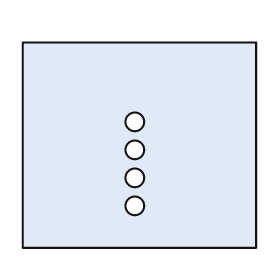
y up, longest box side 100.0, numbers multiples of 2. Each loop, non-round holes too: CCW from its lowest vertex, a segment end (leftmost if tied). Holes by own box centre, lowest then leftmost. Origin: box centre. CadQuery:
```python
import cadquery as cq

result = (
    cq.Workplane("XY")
    .moveTo(-50.0, -44.0)
    .lineTo(50.0, -44.0)
    .lineTo(50.0, 44.0)
    .lineTo(-50.0, 44.0)
    .close()
    .moveTo(-2.0, -26.0)
    .circle(4.0)
    .moveTo(-2.0, -14.0)
    .circle(4.0)
    .moveTo(-2.0, -2.0)
    .circle(4.0)
    .moveTo(-2.0, 10.0)
    .circle(4.0)
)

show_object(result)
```